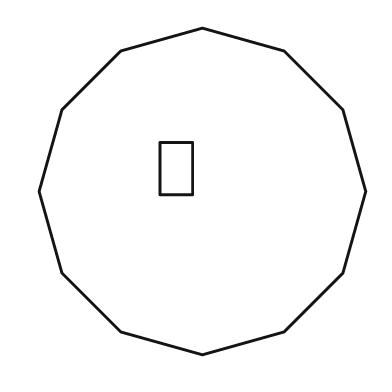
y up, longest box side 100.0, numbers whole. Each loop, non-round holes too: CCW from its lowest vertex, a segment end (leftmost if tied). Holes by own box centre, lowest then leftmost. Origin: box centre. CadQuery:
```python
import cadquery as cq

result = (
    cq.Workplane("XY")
    .moveTo(0.0, -50.0)
    .lineTo(25.0, -43.0)
    .lineTo(43.0, -25.0)
    .lineTo(50.0, 0.0)
    .lineTo(43.0, 25.0)
    .lineTo(25.0, 43.0)
    .lineTo(0.0, 50.0)
    .lineTo(-25.0, 43.0)
    .lineTo(-43.0, 25.0)
    .lineTo(-50.0, 0.0)
    .lineTo(-43.0, -25.0)
    .lineTo(-25.0, -43.0)
    .close()
    .moveTo(-13.0, -1.0)
    .lineTo(-3.0, -1.0)
    .lineTo(-3.0, 15.0)
    .lineTo(-13.0, 15.0)
    .close()
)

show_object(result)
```